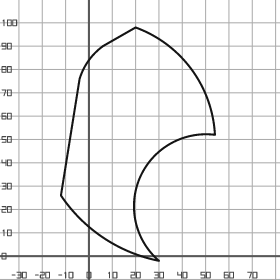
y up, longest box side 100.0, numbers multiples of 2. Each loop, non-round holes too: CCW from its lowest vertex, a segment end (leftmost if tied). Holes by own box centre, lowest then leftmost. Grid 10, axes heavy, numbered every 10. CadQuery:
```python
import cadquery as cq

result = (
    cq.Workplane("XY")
    .moveTo(30.0, -2.0)
    .threePointArc((22.0, 34.0), (54.0, 52.0))
    .threePointArc((44.0, 80.0), (20.0, 98.0))
    .lineTo(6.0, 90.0)
    .threePointArc((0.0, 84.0), (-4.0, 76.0))
    .lineTo(-12.0, 26.0)
    .threePointArc((6.0, 8.0), (30.0, -2.0))
    .close()
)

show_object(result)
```